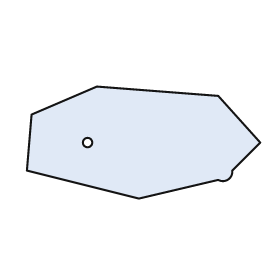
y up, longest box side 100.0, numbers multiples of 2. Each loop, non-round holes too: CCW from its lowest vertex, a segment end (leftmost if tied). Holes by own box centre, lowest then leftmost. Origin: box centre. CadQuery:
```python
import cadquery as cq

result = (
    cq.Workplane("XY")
    .moveTo(-2.0, -24.0)
    .lineTo(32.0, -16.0)
    .threePointArc((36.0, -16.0), (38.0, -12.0))
    .lineTo(50.0, 0.0)
    .lineTo(32.0, 20.0)
    .lineTo(-20.0, 24.0)
    .lineTo(-48.0, 12.0)
    .lineTo(-50.0, -12.0)
    .close()
    .moveTo(-24.0, 0.0)
    .circle(2.0)
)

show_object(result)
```